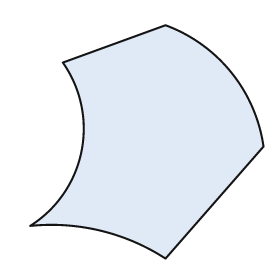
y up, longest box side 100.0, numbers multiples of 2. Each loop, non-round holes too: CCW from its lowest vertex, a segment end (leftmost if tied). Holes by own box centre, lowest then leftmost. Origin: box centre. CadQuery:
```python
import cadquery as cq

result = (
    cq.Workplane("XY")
    .moveTo(8.0, -50.0)
    .lineTo(50.0, -2.0)
    .threePointArc((36.0, 30.0), (8.0, 50.0))
    .lineTo(-36.0, 34.0)
    .threePointArc((-28.0, -4.0), (-50.0, -36.0))
    .threePointArc((-20.0, -38.0), (8.0, -50.0))
    .close()
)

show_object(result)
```